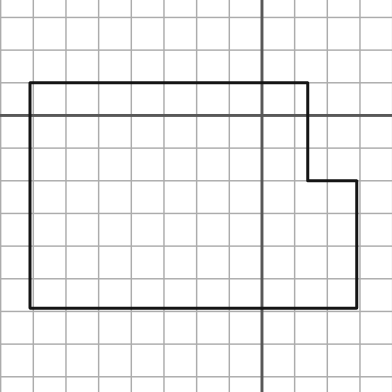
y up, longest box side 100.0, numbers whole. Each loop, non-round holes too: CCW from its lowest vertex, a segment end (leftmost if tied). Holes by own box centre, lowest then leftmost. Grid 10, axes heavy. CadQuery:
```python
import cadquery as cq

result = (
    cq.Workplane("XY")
    .moveTo(-71.0, -59.0)
    .lineTo(29.0, -59.0)
    .lineTo(29.0, -20.0)
    .lineTo(14.0, -20.0)
    .lineTo(14.0, 10.0)
    .lineTo(-71.0, 10.0)
    .close()
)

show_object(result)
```